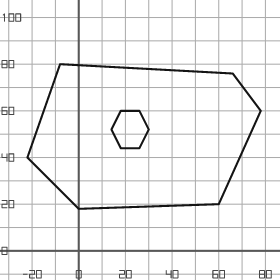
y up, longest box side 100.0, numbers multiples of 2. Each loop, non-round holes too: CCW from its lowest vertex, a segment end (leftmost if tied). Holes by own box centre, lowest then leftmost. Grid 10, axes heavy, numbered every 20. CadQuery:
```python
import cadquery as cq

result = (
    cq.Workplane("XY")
    .moveTo(0.0, 18.0)
    .lineTo(60.0, 20.0)
    .lineTo(78.0, 60.0)
    .lineTo(66.0, 76.0)
    .lineTo(-8.0, 80.0)
    .lineTo(-22.0, 40.0)
    .close()
    .moveTo(18.0, 44.0)
    .lineTo(26.0, 44.0)
    .lineTo(30.0, 52.0)
    .lineTo(26.0, 60.0)
    .lineTo(18.0, 60.0)
    .lineTo(14.0, 52.0)
    .close()
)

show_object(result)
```